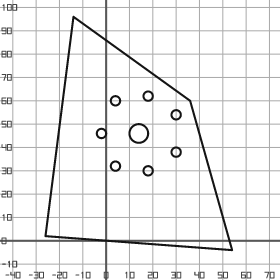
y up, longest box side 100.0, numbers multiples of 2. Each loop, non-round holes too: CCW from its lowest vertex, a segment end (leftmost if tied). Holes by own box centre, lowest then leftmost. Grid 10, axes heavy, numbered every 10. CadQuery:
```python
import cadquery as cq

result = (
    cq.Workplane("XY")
    .moveTo(54.0, -4.0)
    .lineTo(36.0, 60.0)
    .lineTo(-14.0, 96.0)
    .lineTo(-26.0, 2.0)
    .close()
    .moveTo(18.0, 30.0)
    .circle(2.0)
    .moveTo(4.0, 32.0)
    .circle(2.0)
    .moveTo(30.0, 38.0)
    .circle(2.0)
    .moveTo(-2.0, 46.0)
    .circle(2.0)
    .moveTo(14.0, 46.0)
    .circle(4.0)
    .moveTo(30.0, 54.0)
    .circle(2.0)
    .moveTo(4.0, 60.0)
    .circle(2.0)
    .moveTo(18.0, 62.0)
    .circle(2.0)
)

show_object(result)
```